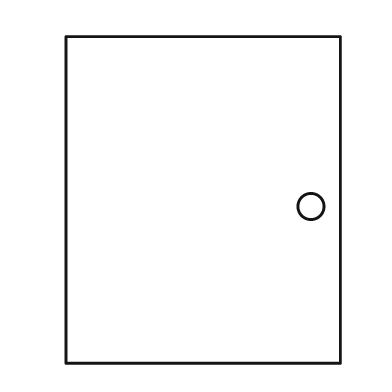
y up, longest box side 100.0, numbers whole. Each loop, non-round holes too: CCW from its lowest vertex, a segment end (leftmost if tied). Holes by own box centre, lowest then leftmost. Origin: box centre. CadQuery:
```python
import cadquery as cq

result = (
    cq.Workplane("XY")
    .moveTo(-42.0, -50.0)
    .lineTo(42.0, -50.0)
    .lineTo(42.0, 50.0)
    .lineTo(-42.0, 50.0)
    .close()
    .moveTo(33.0, -2.0)
    .circle(4.0)
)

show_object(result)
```